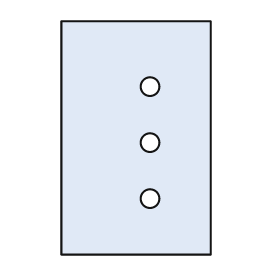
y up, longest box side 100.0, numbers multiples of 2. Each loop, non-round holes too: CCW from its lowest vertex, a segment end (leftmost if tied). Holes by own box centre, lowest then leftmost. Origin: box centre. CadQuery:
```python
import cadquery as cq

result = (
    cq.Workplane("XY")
    .moveTo(-32.0, -50.0)
    .lineTo(32.0, -50.0)
    .lineTo(32.0, 50.0)
    .lineTo(-32.0, 50.0)
    .close()
    .moveTo(6.0, -26.0)
    .circle(4.0)
    .moveTo(6.0, -2.0)
    .circle(4.0)
    .moveTo(6.0, 22.0)
    .circle(4.0)
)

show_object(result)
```